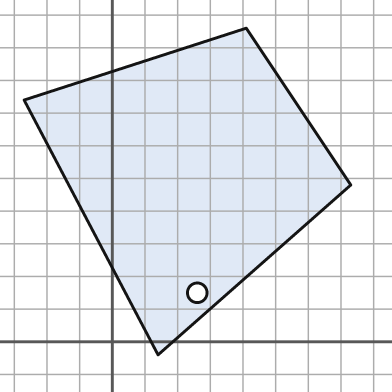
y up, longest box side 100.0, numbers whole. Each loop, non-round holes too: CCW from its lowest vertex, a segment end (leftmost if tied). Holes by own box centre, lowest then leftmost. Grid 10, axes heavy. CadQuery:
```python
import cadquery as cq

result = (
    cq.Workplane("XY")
    .moveTo(14.0, -4.0)
    .lineTo(73.0, 48.0)
    .lineTo(41.0, 96.0)
    .lineTo(-27.0, 74.0)
    .close()
    .moveTo(26.0, 15.0)
    .circle(3.0)
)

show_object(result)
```